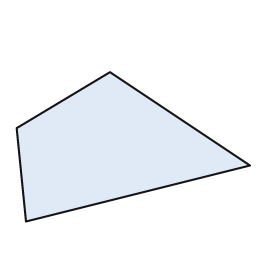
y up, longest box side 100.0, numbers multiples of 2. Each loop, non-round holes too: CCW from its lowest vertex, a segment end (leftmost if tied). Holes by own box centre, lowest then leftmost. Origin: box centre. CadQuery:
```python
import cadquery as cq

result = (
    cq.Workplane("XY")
    .moveTo(-46.0, -32.0)
    .lineTo(50.0, -8.0)
    .lineTo(-10.0, 32.0)
    .lineTo(-50.0, 8.0)
    .close()
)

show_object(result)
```